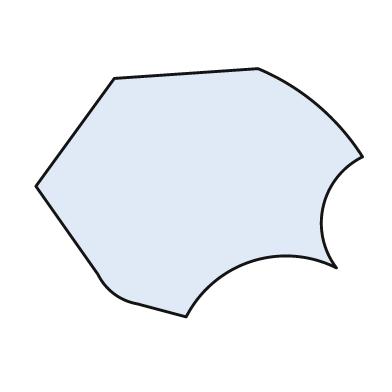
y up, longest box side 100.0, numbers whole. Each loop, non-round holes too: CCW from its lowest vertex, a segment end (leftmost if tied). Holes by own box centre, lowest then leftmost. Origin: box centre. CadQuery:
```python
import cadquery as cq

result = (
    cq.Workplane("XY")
    .moveTo(-4.0, -38.0)
    .threePointArc((16.0, -21.0), (42.0, -23.0))
    .threePointArc((38.0, -4.0), (50.0, 11.0))
    .threePointArc((36.0, 27.0), (18.0, 38.0))
    .lineTo(-26.0, 35.0)
    .lineTo(-50.0, 2.0)
    .lineTo(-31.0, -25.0)
    .threePointArc((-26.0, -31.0), (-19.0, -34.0))
    .close()
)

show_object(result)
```